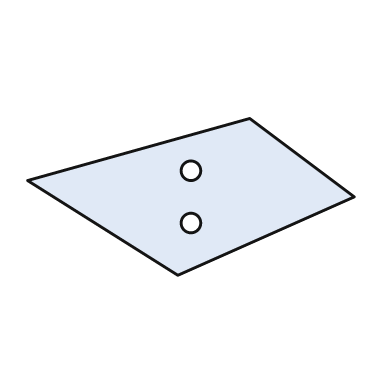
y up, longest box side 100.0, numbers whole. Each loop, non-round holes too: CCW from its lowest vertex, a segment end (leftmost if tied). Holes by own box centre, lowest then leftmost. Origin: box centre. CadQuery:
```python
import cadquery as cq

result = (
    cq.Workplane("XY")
    .moveTo(-4.0, -24.0)
    .lineTo(50.0, 0.0)
    .lineTo(18.0, 24.0)
    .lineTo(-50.0, 5.0)
    .close()
    .moveTo(0.0, -8.0)
    .circle(3.0)
    .moveTo(0.0, 8.0)
    .circle(3.0)
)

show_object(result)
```